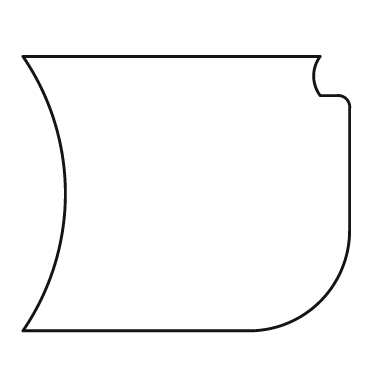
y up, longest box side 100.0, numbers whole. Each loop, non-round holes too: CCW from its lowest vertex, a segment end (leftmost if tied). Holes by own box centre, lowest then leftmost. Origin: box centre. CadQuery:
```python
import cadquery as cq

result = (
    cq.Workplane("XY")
    .moveTo(-50.0, -42.0)
    .lineTo(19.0, -42.0)
    .threePointArc((41.0, -33.0), (50.0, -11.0))
    .lineTo(50.0, 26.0)
    .threePointArc((49.0, 29.0), (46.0, 30.0))
    .lineTo(41.0, 30.0)
    .threePointArc((39.0, 36.0), (41.0, 42.0))
    .lineTo(-50.0, 42.0)
    .threePointArc((-37.0, 0.0), (-50.0, -42.0))
    .close()
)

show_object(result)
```